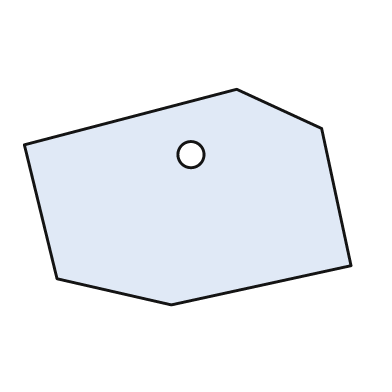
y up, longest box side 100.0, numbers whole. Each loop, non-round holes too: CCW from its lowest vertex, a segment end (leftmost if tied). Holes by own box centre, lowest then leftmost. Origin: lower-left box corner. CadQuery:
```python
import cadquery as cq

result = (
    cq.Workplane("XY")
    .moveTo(45.0, 0.0)
    .lineTo(100.0, 12.0)
    .lineTo(91.0, 54.0)
    .lineTo(65.0, 66.0)
    .lineTo(0.0, 49.0)
    .lineTo(10.0, 8.0)
    .close()
    .moveTo(51.0, 46.0)
    .circle(4.0)
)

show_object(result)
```